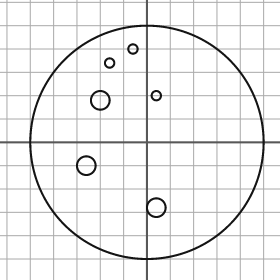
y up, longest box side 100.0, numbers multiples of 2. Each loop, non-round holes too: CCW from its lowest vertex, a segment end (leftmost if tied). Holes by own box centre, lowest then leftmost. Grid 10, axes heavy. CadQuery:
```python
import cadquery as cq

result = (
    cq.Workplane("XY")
    .moveTo(0.0, 0.0)
    .circle(50.0)
    .moveTo(4.0, -28.0)
    .circle(4.0)
    .moveTo(-26.0, -10.0)
    .circle(4.0)
    .moveTo(-20.0, 18.0)
    .circle(4.0)
    .moveTo(4.0, 20.0)
    .circle(2.0)
    .moveTo(-16.0, 34.0)
    .circle(2.0)
    .moveTo(-6.0, 40.0)
    .circle(2.0)
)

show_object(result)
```